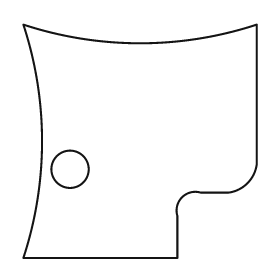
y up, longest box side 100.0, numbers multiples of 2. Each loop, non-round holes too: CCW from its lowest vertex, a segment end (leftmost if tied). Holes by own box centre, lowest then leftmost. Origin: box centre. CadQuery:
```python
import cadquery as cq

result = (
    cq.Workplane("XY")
    .moveTo(-50.0, -50.0)
    .lineTo(16.0, -50.0)
    .lineTo(16.0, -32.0)
    .threePointArc((18.0, -24.0), (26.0, -22.0))
    .lineTo(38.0, -22.0)
    .threePointArc((46.0, -18.0), (50.0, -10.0))
    .lineTo(50.0, 50.0)
    .threePointArc((0.0, 42.0), (-50.0, 50.0))
    .threePointArc((-42.0, 0.0), (-50.0, -50.0))
    .close()
    .moveTo(-30.0, -12.0)
    .circle(8.0)
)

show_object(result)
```